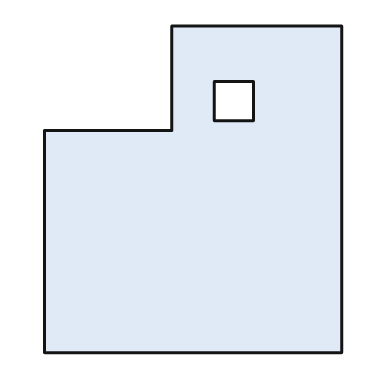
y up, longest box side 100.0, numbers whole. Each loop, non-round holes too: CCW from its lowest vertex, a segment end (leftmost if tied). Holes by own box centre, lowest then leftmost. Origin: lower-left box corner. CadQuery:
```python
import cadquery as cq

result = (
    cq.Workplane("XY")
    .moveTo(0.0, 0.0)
    .lineTo(91.0, 0.0)
    .lineTo(91.0, 100.0)
    .lineTo(39.0, 100.0)
    .lineTo(39.0, 68.0)
    .lineTo(0.0, 68.0)
    .close()
    .moveTo(52.0, 71.0)
    .lineTo(64.0, 71.0)
    .lineTo(64.0, 83.0)
    .lineTo(52.0, 83.0)
    .close()
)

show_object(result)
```